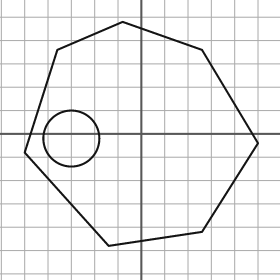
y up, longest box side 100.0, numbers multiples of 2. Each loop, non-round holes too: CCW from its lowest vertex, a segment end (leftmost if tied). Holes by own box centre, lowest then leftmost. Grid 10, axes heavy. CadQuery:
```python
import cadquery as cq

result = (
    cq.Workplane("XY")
    .moveTo(-14.0, -48.0)
    .lineTo(26.0, -42.0)
    .lineTo(50.0, -4.0)
    .lineTo(26.0, 36.0)
    .lineTo(-8.0, 48.0)
    .lineTo(-36.0, 36.0)
    .lineTo(-50.0, -8.0)
    .close()
    .moveTo(-30.0, -2.0)
    .circle(12.0)
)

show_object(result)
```